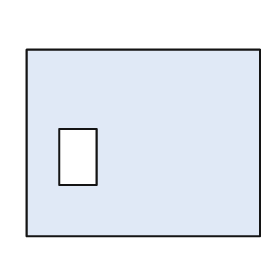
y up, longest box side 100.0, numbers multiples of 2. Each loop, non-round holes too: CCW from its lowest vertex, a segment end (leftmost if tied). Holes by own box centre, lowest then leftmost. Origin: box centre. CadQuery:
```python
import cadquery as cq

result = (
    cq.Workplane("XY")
    .moveTo(-50.0, -40.0)
    .lineTo(50.0, -40.0)
    .lineTo(50.0, 40.0)
    .lineTo(-50.0, 40.0)
    .close()
    .moveTo(-36.0, -18.0)
    .lineTo(-20.0, -18.0)
    .lineTo(-20.0, 6.0)
    .lineTo(-36.0, 6.0)
    .close()
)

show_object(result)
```